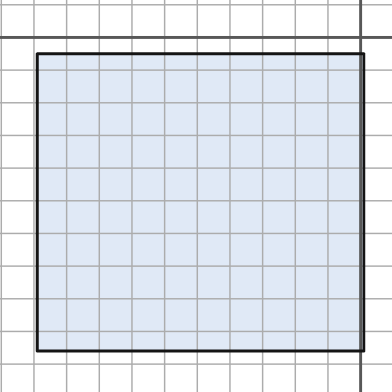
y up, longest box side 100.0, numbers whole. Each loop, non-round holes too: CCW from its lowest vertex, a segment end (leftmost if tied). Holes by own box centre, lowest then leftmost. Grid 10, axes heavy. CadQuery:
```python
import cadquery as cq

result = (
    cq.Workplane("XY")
    .moveTo(-99.0, -96.0)
    .lineTo(1.0, -96.0)
    .lineTo(1.0, -5.0)
    .lineTo(-99.0, -5.0)
    .close()
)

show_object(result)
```